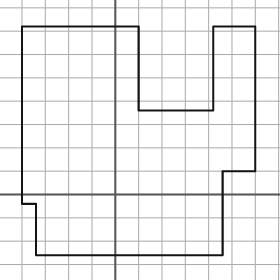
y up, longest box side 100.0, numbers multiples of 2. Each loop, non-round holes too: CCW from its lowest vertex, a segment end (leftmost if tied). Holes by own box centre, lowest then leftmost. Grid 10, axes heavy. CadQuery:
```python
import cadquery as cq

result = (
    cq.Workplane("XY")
    .moveTo(-34.0, -26.0)
    .lineTo(46.0, -26.0)
    .lineTo(46.0, 10.0)
    .lineTo(60.0, 10.0)
    .lineTo(60.0, 72.0)
    .lineTo(42.0, 72.0)
    .lineTo(42.0, 36.0)
    .lineTo(10.0, 36.0)
    .lineTo(10.0, 72.0)
    .lineTo(-40.0, 72.0)
    .lineTo(-40.0, -4.0)
    .lineTo(-34.0, -4.0)
    .close()
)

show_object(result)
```